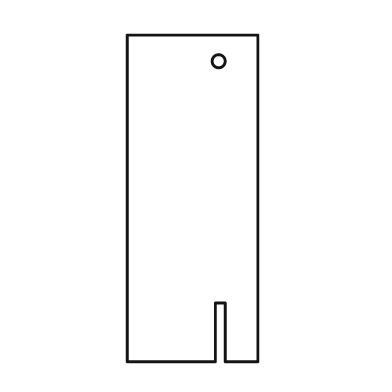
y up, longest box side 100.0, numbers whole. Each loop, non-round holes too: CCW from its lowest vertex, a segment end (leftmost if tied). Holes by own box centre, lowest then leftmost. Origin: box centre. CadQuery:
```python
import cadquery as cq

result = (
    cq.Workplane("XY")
    .moveTo(-20.0, -50.0)
    .lineTo(7.0, -50.0)
    .lineTo(7.0, -32.0)
    .lineTo(10.0, -32.0)
    .lineTo(10.0, -50.0)
    .lineTo(20.0, -50.0)
    .lineTo(20.0, 50.0)
    .lineTo(-20.0, 50.0)
    .close()
    .moveTo(8.0, 42.0)
    .circle(2.0)
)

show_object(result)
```